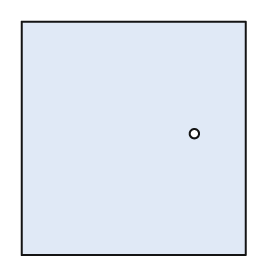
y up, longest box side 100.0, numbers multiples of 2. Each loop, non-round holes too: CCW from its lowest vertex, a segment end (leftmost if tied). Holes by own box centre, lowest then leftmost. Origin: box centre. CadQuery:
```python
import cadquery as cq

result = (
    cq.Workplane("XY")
    .moveTo(-48.0, -50.0)
    .lineTo(48.0, -50.0)
    .lineTo(48.0, 50.0)
    .lineTo(-48.0, 50.0)
    .close()
    .moveTo(26.0, 2.0)
    .circle(2.0)
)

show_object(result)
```